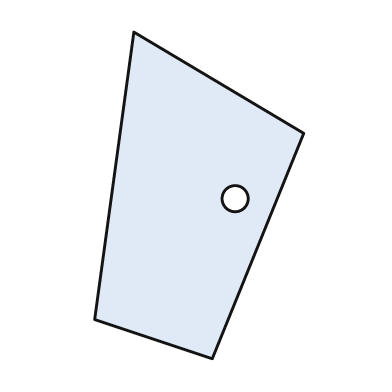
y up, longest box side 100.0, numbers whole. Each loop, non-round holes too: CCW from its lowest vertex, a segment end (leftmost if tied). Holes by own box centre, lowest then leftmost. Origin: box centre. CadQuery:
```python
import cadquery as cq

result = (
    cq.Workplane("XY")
    .moveTo(4.0, -50.0)
    .lineTo(32.0, 19.0)
    .lineTo(-20.0, 50.0)
    .lineTo(-32.0, -38.0)
    .close()
    .moveTo(11.0, -1.0)
    .circle(4.0)
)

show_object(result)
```